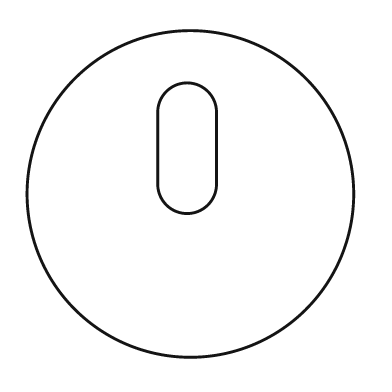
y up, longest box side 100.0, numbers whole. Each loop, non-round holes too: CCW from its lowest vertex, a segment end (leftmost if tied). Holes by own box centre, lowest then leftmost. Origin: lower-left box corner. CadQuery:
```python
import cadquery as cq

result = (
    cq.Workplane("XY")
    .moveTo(50.0, 50.0)
    .circle(50.0)
    .moveTo(40.0, 53.0)
    .threePointArc((49.0, 44.0), (58.0, 53.0))
    .lineTo(58.0, 75.0)
    .threePointArc((49.0, 84.0), (40.0, 75.0))
    .close()
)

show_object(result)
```